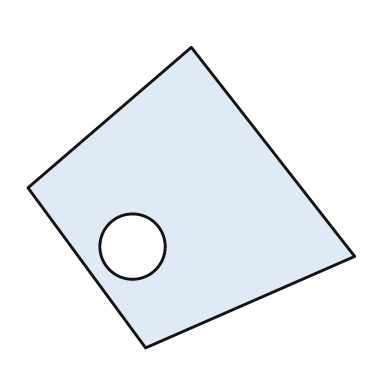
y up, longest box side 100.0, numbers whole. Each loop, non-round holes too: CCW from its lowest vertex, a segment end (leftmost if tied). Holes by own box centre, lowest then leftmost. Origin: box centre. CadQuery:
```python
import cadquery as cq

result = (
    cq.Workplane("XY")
    .moveTo(-14.0, -46.0)
    .lineTo(50.0, -18.0)
    .lineTo(0.0, 46.0)
    .lineTo(-50.0, 3.0)
    .close()
    .moveTo(-18.0, -15.0)
    .circle(10.0)
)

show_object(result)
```